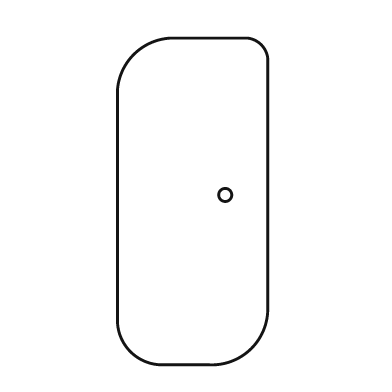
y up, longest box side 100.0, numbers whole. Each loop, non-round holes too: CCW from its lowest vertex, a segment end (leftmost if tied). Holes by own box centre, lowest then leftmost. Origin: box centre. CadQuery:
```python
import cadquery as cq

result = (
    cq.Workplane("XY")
    .moveTo(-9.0, -50.0)
    .lineTo(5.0, -50.0)
    .threePointArc((18.0, -45.0), (23.0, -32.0))
    .lineTo(23.0, 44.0)
    .threePointArc((21.0, 48.0), (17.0, 50.0))
    .lineTo(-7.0, 50.0)
    .threePointArc((-18.0, 45.0), (-23.0, 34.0))
    .lineTo(-23.0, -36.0)
    .threePointArc((-19.0, -46.0), (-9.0, -50.0))
    .close()
    .moveTo(10.0, 2.0)
    .circle(2.0)
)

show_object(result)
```